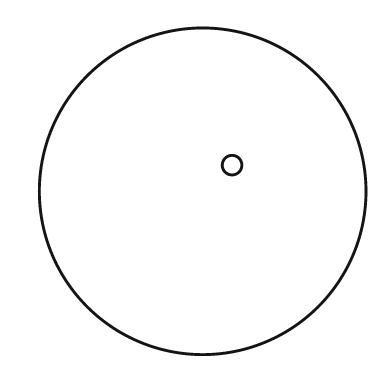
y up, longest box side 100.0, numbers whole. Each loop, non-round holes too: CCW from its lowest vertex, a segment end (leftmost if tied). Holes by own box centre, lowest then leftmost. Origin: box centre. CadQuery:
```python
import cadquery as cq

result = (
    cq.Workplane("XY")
    .moveTo(0.0, 0.0)
    .circle(50.0)
    .moveTo(9.0, 8.0)
    .circle(3.0)
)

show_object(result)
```